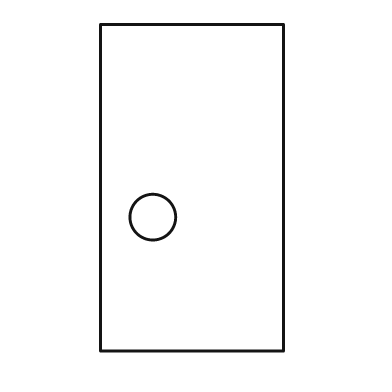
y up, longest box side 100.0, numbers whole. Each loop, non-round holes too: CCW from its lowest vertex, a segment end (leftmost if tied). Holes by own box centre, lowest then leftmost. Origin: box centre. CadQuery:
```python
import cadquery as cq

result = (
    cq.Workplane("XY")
    .moveTo(-28.0, -50.0)
    .lineTo(28.0, -50.0)
    .lineTo(28.0, 50.0)
    .lineTo(-28.0, 50.0)
    .close()
    .moveTo(-12.0, -9.0)
    .circle(7.0)
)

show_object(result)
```